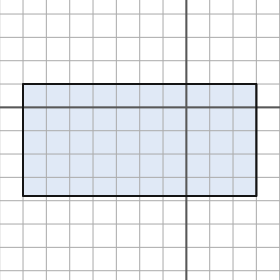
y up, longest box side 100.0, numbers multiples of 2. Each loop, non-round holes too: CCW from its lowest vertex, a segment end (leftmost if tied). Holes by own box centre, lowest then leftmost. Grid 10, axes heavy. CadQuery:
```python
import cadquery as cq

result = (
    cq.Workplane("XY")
    .moveTo(-70.0, -38.0)
    .lineTo(30.0, -38.0)
    .lineTo(30.0, 10.0)
    .lineTo(-70.0, 10.0)
    .close()
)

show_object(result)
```